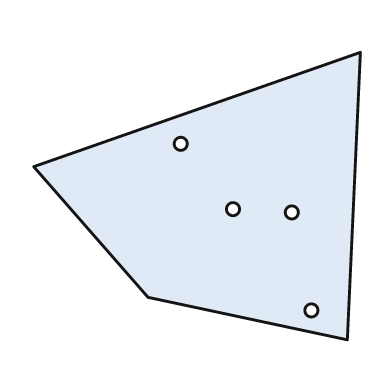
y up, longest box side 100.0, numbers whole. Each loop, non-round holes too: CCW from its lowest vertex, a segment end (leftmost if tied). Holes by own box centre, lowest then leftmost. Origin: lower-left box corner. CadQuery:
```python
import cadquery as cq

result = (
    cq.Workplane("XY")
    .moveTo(96.0, 0.0)
    .lineTo(100.0, 88.0)
    .lineTo(0.0, 53.0)
    .lineTo(35.0, 13.0)
    .close()
    .moveTo(85.0, 9.0)
    .circle(2.0)
    .moveTo(79.0, 39.0)
    .circle(2.0)
    .moveTo(61.0, 40.0)
    .circle(2.0)
    .moveTo(45.0, 60.0)
    .circle(2.0)
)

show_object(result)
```